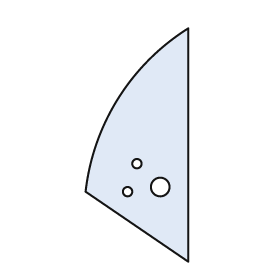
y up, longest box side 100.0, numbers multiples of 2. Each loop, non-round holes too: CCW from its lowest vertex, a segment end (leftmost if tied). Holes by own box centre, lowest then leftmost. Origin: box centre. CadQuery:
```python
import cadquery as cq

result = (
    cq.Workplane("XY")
    .moveTo(22.0, -50.0)
    .lineTo(22.0, 50.0)
    .threePointArc((-8.0, 20.0), (-22.0, -20.0))
    .close()
    .moveTo(-4.0, -20.0)
    .circle(2.0)
    .moveTo(10.0, -18.0)
    .circle(4.0)
    .moveTo(0.0, -8.0)
    .circle(2.0)
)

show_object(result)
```